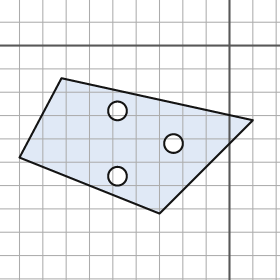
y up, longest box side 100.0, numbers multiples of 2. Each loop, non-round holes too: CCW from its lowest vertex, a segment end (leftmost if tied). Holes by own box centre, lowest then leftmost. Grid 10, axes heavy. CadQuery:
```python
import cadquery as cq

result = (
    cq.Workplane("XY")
    .moveTo(-30.0, -72.0)
    .lineTo(10.0, -32.0)
    .lineTo(-72.0, -14.0)
    .lineTo(-90.0, -48.0)
    .close()
    .moveTo(-48.0, -56.0)
    .circle(4.0)
    .moveTo(-24.0, -42.0)
    .circle(4.0)
    .moveTo(-48.0, -28.0)
    .circle(4.0)
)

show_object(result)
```